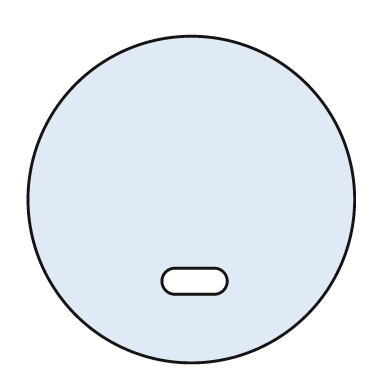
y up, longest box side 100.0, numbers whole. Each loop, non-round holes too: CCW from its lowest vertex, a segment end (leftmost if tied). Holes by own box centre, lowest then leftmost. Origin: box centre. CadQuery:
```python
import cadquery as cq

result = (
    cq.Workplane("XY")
    .moveTo(0.0, 0.0)
    .circle(50.0)
    .moveTo(-5.0, -29.0)
    .lineTo(7.0, -29.0)
    .threePointArc((11.0, -25.0), (7.0, -21.0))
    .lineTo(-5.0, -21.0)
    .threePointArc((-9.0, -25.0), (-5.0, -29.0))
    .close()
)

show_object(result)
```